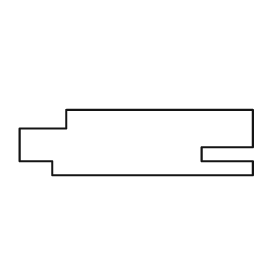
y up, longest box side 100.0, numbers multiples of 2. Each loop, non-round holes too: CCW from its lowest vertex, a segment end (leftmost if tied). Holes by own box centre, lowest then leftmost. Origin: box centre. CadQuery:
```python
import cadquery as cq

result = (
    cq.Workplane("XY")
    .moveTo(-36.0, -14.0)
    .lineTo(50.0, -14.0)
    .lineTo(50.0, -8.0)
    .lineTo(28.0, -8.0)
    .lineTo(28.0, -2.0)
    .lineTo(50.0, -2.0)
    .lineTo(50.0, 14.0)
    .lineTo(-30.0, 14.0)
    .lineTo(-30.0, 6.0)
    .lineTo(-50.0, 6.0)
    .lineTo(-50.0, -8.0)
    .lineTo(-36.0, -8.0)
    .close()
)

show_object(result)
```